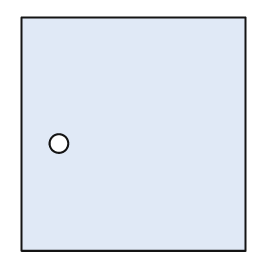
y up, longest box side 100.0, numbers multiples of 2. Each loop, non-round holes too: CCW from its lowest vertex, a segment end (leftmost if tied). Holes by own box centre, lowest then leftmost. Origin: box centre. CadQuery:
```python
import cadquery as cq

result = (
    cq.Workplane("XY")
    .moveTo(-48.0, -50.0)
    .lineTo(48.0, -50.0)
    .lineTo(48.0, 50.0)
    .lineTo(-48.0, 50.0)
    .close()
    .moveTo(-32.0, -4.0)
    .circle(4.0)
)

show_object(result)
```